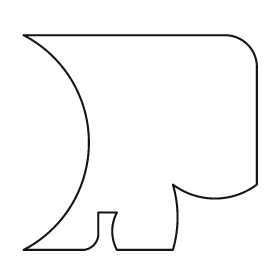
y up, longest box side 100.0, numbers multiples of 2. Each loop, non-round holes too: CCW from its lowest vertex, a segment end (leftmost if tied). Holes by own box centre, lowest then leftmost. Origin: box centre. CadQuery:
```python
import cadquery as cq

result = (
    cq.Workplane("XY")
    .moveTo(-50.0, -46.0)
    .lineTo(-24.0, -46.0)
    .threePointArc((-20.0, -44.0), (-18.0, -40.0))
    .lineTo(-18.0, -30.0)
    .lineTo(-10.0, -30.0)
    .threePointArc((-12.0, -38.0), (-10.0, -46.0))
    .lineTo(14.0, -46.0)
    .threePointArc((16.0, -32.0), (14.0, -18.0))
    .threePointArc((32.0, -24.0), (50.0, -18.0))
    .lineTo(50.0, 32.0)
    .threePointArc((46.0, 42.0), (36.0, 46.0))
    .lineTo(-50.0, 46.0)
    .threePointArc((-22.0, 0.0), (-50.0, -46.0))
    .close()
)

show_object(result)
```